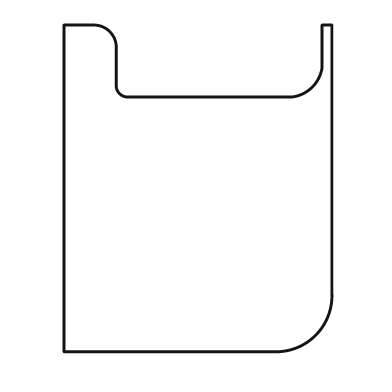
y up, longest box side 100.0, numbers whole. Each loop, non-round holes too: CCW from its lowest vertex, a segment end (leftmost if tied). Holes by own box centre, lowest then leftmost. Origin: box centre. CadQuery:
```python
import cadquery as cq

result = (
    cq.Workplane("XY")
    .moveTo(-41.0, -50.0)
    .lineTo(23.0, -50.0)
    .threePointArc((36.0, -45.0), (41.0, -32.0))
    .lineTo(41.0, 50.0)
    .lineTo(38.0, 50.0)
    .lineTo(38.0, 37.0)
    .threePointArc((35.0, 31.0), (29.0, 28.0))
    .lineTo(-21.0, 28.0)
    .threePointArc((-24.0, 29.0), (-25.0, 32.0))
    .lineTo(-25.0, 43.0)
    .threePointArc((-27.0, 48.0), (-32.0, 50.0))
    .lineTo(-41.0, 50.0)
    .close()
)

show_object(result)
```